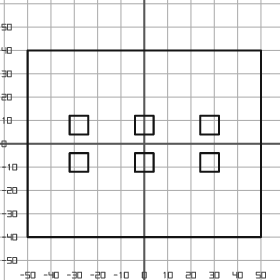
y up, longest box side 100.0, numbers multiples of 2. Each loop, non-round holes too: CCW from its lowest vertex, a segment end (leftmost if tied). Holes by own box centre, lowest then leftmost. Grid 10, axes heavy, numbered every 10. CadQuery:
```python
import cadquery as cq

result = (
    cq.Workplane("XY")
    .moveTo(-50.0, -40.0)
    .lineTo(50.0, -40.0)
    .lineTo(50.0, 40.0)
    .lineTo(-50.0, 40.0)
    .close()
    .moveTo(-32.0, -12.0)
    .lineTo(-24.0, -12.0)
    .lineTo(-24.0, -4.0)
    .lineTo(-32.0, -4.0)
    .close()
    .moveTo(-4.0, -12.0)
    .lineTo(4.0, -12.0)
    .lineTo(4.0, -4.0)
    .lineTo(-4.0, -4.0)
    .close()
    .moveTo(24.0, -12.0)
    .lineTo(32.0, -12.0)
    .lineTo(32.0, -4.0)
    .lineTo(24.0, -4.0)
    .close()
    .moveTo(-32.0, 4.0)
    .lineTo(-24.0, 4.0)
    .lineTo(-24.0, 12.0)
    .lineTo(-32.0, 12.0)
    .close()
    .moveTo(-4.0, 4.0)
    .lineTo(4.0, 4.0)
    .lineTo(4.0, 12.0)
    .lineTo(-4.0, 12.0)
    .close()
    .moveTo(24.0, 4.0)
    .lineTo(32.0, 4.0)
    .lineTo(32.0, 12.0)
    .lineTo(24.0, 12.0)
    .close()
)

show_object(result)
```